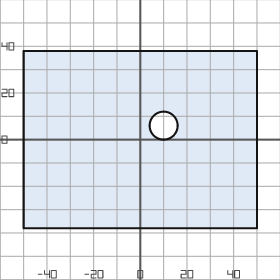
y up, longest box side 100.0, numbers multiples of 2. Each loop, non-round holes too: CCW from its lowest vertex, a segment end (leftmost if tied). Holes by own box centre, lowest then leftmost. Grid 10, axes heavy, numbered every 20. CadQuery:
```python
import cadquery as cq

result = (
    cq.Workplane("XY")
    .moveTo(-50.0, -38.0)
    .lineTo(50.0, -38.0)
    .lineTo(50.0, 38.0)
    .lineTo(-50.0, 38.0)
    .close()
    .moveTo(10.0, 6.0)
    .circle(6.0)
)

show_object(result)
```